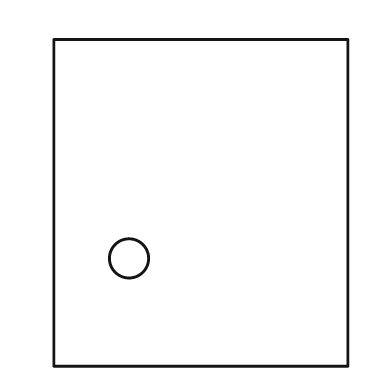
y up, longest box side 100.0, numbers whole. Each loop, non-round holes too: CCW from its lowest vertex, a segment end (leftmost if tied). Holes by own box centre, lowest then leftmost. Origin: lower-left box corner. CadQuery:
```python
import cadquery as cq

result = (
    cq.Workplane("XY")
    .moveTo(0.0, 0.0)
    .lineTo(90.0, 0.0)
    .lineTo(90.0, 100.0)
    .lineTo(0.0, 100.0)
    .close()
    .moveTo(23.0, 33.0)
    .circle(6.0)
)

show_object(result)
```